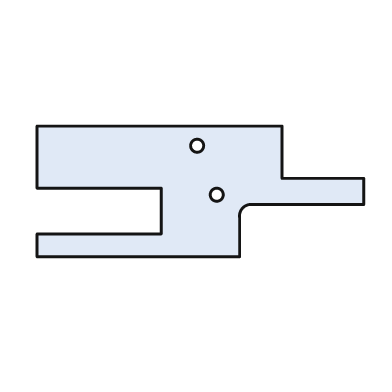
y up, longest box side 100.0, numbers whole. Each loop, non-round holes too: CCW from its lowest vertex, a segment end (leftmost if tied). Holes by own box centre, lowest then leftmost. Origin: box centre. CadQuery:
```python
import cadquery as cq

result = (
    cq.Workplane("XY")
    .moveTo(-50.0, -20.0)
    .lineTo(12.0, -20.0)
    .lineTo(12.0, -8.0)
    .threePointArc((13.0, -5.0), (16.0, -4.0))
    .lineTo(50.0, -4.0)
    .lineTo(50.0, 4.0)
    .lineTo(25.0, 4.0)
    .lineTo(25.0, 20.0)
    .lineTo(-50.0, 20.0)
    .lineTo(-50.0, 1.0)
    .lineTo(-12.0, 1.0)
    .lineTo(-12.0, -13.0)
    .lineTo(-50.0, -13.0)
    .close()
    .moveTo(5.0, -1.0)
    .circle(2.0)
    .moveTo(-1.0, 14.0)
    .circle(2.0)
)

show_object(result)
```